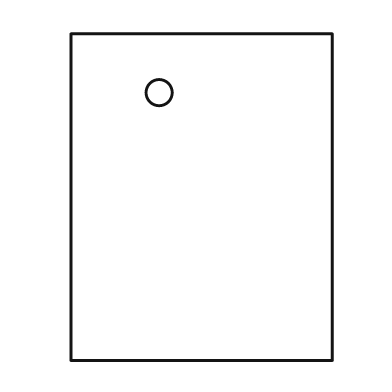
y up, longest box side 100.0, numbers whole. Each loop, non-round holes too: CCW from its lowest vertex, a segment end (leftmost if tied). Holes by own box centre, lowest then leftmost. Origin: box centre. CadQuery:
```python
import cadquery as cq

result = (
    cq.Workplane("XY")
    .moveTo(-40.0, -50.0)
    .lineTo(40.0, -50.0)
    .lineTo(40.0, 50.0)
    .lineTo(-40.0, 50.0)
    .close()
    .moveTo(-13.0, 32.0)
    .circle(4.0)
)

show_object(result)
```